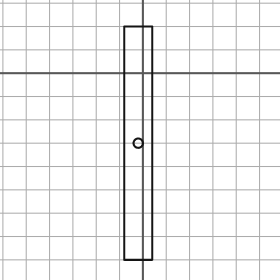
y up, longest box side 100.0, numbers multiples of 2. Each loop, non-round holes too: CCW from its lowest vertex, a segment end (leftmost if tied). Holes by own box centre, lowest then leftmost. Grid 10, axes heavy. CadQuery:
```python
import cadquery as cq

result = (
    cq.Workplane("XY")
    .moveTo(-8.0, -80.0)
    .lineTo(4.0, -80.0)
    .lineTo(4.0, 20.0)
    .lineTo(-8.0, 20.0)
    .close()
    .moveTo(-2.0, -30.0)
    .circle(2.0)
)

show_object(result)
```